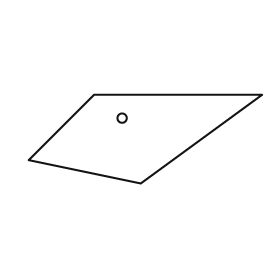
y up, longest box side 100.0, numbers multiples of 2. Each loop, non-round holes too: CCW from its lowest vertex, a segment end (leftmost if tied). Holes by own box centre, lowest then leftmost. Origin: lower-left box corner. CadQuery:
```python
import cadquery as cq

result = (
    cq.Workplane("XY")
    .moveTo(48.0, 0.0)
    .lineTo(100.0, 38.0)
    .lineTo(28.0, 38.0)
    .lineTo(0.0, 10.0)
    .close()
    .moveTo(40.0, 28.0)
    .circle(2.0)
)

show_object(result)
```